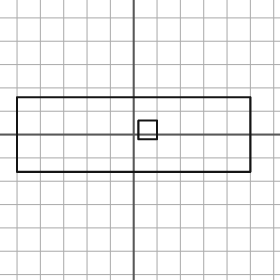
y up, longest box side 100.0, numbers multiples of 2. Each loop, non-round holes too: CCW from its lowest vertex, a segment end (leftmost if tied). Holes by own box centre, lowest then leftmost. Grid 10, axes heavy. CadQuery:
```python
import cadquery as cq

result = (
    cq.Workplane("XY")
    .moveTo(-50.0, -16.0)
    .lineTo(50.0, -16.0)
    .lineTo(50.0, 16.0)
    .lineTo(-50.0, 16.0)
    .close()
    .moveTo(2.0, -2.0)
    .lineTo(10.0, -2.0)
    .lineTo(10.0, 6.0)
    .lineTo(2.0, 6.0)
    .close()
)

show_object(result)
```